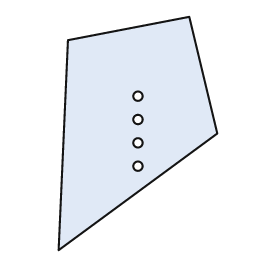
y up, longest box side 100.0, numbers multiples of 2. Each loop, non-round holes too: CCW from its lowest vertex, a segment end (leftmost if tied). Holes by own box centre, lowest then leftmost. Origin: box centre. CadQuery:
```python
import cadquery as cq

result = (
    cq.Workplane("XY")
    .moveTo(-34.0, -50.0)
    .lineTo(34.0, 0.0)
    .lineTo(22.0, 50.0)
    .lineTo(-30.0, 40.0)
    .close()
    .moveTo(0.0, -14.0)
    .circle(2.0)
    .moveTo(0.0, -4.0)
    .circle(2.0)
    .moveTo(0.0, 6.0)
    .circle(2.0)
    .moveTo(0.0, 16.0)
    .circle(2.0)
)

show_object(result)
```